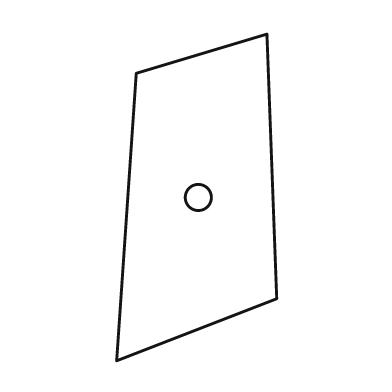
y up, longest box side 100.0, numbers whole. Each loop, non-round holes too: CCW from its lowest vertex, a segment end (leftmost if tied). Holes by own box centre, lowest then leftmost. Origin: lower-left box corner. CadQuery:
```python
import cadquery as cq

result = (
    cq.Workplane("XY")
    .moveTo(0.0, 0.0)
    .lineTo(49.0, 19.0)
    .lineTo(46.0, 100.0)
    .lineTo(6.0, 88.0)
    .close()
    .moveTo(25.0, 50.0)
    .circle(4.0)
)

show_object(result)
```